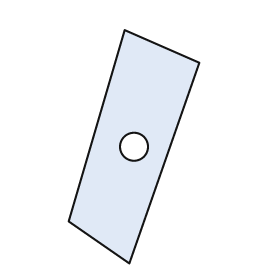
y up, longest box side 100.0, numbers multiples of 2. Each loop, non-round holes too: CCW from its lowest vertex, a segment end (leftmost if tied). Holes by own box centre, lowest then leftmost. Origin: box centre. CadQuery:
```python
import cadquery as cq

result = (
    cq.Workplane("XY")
    .moveTo(-2.0, -50.0)
    .lineTo(28.0, 36.0)
    .lineTo(-4.0, 50.0)
    .lineTo(-28.0, -32.0)
    .close()
    .moveTo(0.0, 0.0)
    .circle(6.0)
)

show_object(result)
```